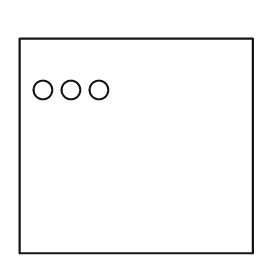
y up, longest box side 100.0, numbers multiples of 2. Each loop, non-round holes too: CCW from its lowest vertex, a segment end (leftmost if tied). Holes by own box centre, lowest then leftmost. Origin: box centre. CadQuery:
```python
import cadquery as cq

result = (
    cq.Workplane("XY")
    .moveTo(-50.0, -46.0)
    .lineTo(50.0, -46.0)
    .lineTo(50.0, 46.0)
    .lineTo(-50.0, 46.0)
    .close()
    .moveTo(-40.0, 24.0)
    .circle(4.0)
    .moveTo(-28.0, 24.0)
    .circle(4.0)
    .moveTo(-16.0, 24.0)
    .circle(4.0)
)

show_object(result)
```